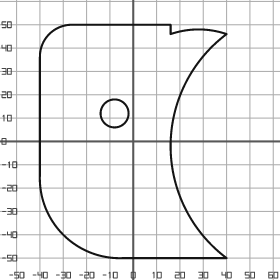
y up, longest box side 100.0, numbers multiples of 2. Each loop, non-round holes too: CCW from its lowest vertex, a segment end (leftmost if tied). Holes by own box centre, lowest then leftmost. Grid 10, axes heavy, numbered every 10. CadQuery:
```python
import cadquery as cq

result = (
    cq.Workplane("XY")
    .moveTo(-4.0, -50.0)
    .lineTo(40.0, -50.0)
    .threePointArc((16.0, -2.0), (40.0, 46.0))
    .threePointArc((28.0, 48.0), (16.0, 46.0))
    .lineTo(16.0, 50.0)
    .lineTo(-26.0, 50.0)
    .threePointArc((-36.0, 46.0), (-40.0, 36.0))
    .lineTo(-40.0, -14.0)
    .threePointArc((-30.0, -40.0), (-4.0, -50.0))
    .close()
    .moveTo(-8.0, 12.0)
    .circle(6.0)
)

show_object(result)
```